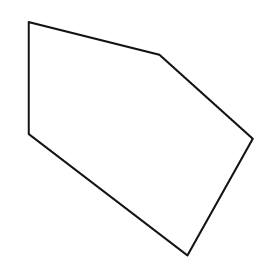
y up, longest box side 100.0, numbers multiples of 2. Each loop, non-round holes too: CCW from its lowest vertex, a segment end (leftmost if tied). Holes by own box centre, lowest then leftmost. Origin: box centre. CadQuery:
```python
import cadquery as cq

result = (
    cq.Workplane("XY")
    .moveTo(20.0, -50.0)
    .lineTo(48.0, 0.0)
    .lineTo(8.0, 36.0)
    .lineTo(-48.0, 50.0)
    .lineTo(-48.0, 2.0)
    .close()
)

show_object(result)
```